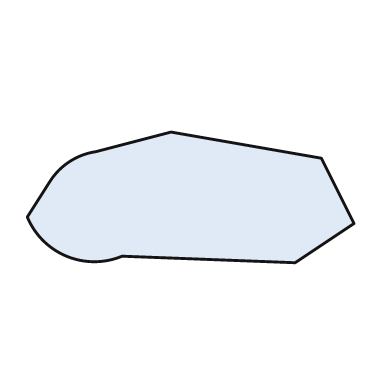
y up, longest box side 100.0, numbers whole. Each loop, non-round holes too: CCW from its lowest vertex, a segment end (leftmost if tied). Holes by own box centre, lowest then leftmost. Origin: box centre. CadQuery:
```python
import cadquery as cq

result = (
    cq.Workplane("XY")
    .moveTo(32.0, -20.0)
    .lineTo(50.0, -8.0)
    .lineTo(40.0, 12.0)
    .lineTo(-6.0, 20.0)
    .lineTo(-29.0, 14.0)
    .threePointArc((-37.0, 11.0), (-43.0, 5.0))
    .lineTo(-50.0, -6.0)
    .threePointArc((-38.0, -18.0), (-21.0, -18.0))
    .close()
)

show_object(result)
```